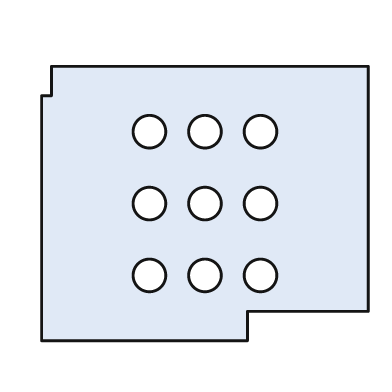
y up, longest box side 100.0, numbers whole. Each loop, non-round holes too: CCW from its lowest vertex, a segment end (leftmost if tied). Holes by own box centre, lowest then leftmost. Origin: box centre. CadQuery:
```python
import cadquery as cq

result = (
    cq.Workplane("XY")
    .moveTo(-50.0, -42.0)
    .lineTo(13.0, -42.0)
    .lineTo(13.0, -33.0)
    .lineTo(50.0, -33.0)
    .lineTo(50.0, 42.0)
    .lineTo(-47.0, 42.0)
    .lineTo(-47.0, 33.0)
    .lineTo(-50.0, 33.0)
    .close()
    .moveTo(-17.0, -22.0)
    .circle(5.0)
    .moveTo(0.0, -22.0)
    .circle(5.0)
    .moveTo(17.0, -22.0)
    .circle(5.0)
    .moveTo(-17.0, 0.0)
    .circle(5.0)
    .moveTo(0.0, 0.0)
    .circle(5.0)
    .moveTo(17.0, 0.0)
    .circle(5.0)
    .moveTo(-17.0, 22.0)
    .circle(5.0)
    .moveTo(0.0, 22.0)
    .circle(5.0)
    .moveTo(17.0, 22.0)
    .circle(5.0)
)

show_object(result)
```